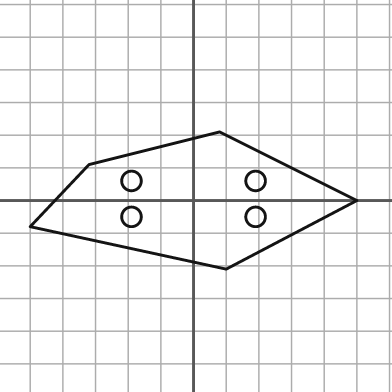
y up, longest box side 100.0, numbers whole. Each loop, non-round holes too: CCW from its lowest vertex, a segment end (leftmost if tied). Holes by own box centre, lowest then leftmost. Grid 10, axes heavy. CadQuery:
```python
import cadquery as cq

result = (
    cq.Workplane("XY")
    .moveTo(10.0, -21.0)
    .lineTo(50.0, 0.0)
    .lineTo(8.0, 21.0)
    .lineTo(-32.0, 11.0)
    .lineTo(-50.0, -8.0)
    .close()
    .moveTo(-19.0, -5.0)
    .circle(3.0)
    .moveTo(19.0, -5.0)
    .circle(3.0)
    .moveTo(-19.0, 6.0)
    .circle(3.0)
    .moveTo(19.0, 6.0)
    .circle(3.0)
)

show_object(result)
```